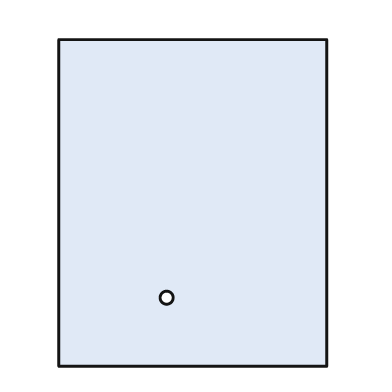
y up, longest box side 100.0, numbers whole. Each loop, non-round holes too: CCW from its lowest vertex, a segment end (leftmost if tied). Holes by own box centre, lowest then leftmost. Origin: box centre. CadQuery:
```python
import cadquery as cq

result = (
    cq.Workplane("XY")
    .moveTo(-41.0, -50.0)
    .lineTo(41.0, -50.0)
    .lineTo(41.0, 50.0)
    .lineTo(-41.0, 50.0)
    .close()
    .moveTo(-8.0, -29.0)
    .circle(2.0)
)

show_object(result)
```